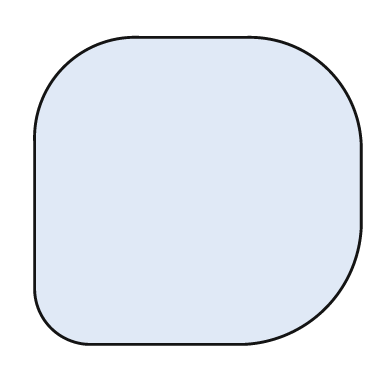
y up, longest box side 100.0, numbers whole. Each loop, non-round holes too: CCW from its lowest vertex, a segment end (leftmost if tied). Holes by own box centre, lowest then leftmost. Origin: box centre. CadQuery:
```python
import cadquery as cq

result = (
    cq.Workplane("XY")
    .moveTo(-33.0, -47.0)
    .lineTo(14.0, -47.0)
    .threePointArc((39.0, -36.0), (50.0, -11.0))
    .lineTo(50.0, 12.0)
    .threePointArc((40.0, 37.0), (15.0, 47.0))
    .lineTo(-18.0, 47.0)
    .threePointArc((-41.0, 38.0), (-50.0, 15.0))
    .lineTo(-50.0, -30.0)
    .threePointArc((-45.0, -42.0), (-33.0, -47.0))
    .close()
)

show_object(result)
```